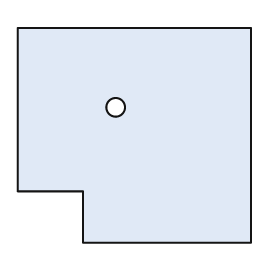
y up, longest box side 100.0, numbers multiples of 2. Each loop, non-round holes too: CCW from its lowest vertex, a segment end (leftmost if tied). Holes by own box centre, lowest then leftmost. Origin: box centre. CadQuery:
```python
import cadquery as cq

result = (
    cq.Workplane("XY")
    .moveTo(-22.0, -46.0)
    .lineTo(50.0, -46.0)
    .lineTo(50.0, 46.0)
    .lineTo(-50.0, 46.0)
    .lineTo(-50.0, -24.0)
    .lineTo(-22.0, -24.0)
    .close()
    .moveTo(-8.0, 12.0)
    .circle(4.0)
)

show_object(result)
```